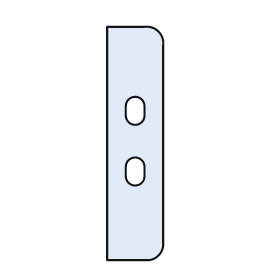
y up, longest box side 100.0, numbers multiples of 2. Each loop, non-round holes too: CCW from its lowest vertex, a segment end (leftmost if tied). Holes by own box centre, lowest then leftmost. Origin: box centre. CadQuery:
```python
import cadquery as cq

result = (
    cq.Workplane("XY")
    .moveTo(-12.0, -50.0)
    .lineTo(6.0, -50.0)
    .threePointArc((10.0, -48.0), (12.0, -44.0))
    .lineTo(12.0, 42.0)
    .threePointArc((10.0, 48.0), (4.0, 50.0))
    .lineTo(-12.0, 50.0)
    .close()
    .moveTo(-4.0, -14.0)
    .threePointArc((0.0, -18.0), (4.0, -14.0))
    .lineTo(4.0, -10.0)
    .threePointArc((0.0, -6.0), (-4.0, -10.0))
    .close()
    .moveTo(-4.0, 12.0)
    .threePointArc((0.0, 8.0), (4.0, 12.0))
    .lineTo(4.0, 16.0)
    .threePointArc((0.0, 20.0), (-4.0, 16.0))
    .close()
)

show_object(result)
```